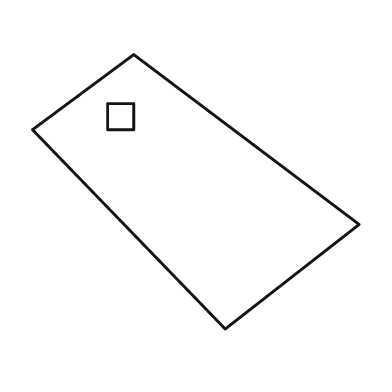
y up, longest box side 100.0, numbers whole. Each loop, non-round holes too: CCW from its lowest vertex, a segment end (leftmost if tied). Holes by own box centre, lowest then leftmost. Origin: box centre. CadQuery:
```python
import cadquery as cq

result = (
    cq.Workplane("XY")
    .moveTo(9.0, -42.0)
    .lineTo(50.0, -10.0)
    .lineTo(-19.0, 42.0)
    .lineTo(-50.0, 19.0)
    .close()
    .moveTo(-27.0, 19.0)
    .lineTo(-19.0, 19.0)
    .lineTo(-19.0, 27.0)
    .lineTo(-27.0, 27.0)
    .close()
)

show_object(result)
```